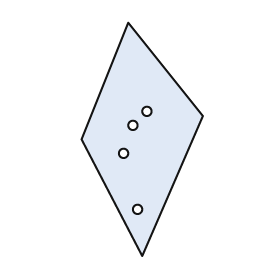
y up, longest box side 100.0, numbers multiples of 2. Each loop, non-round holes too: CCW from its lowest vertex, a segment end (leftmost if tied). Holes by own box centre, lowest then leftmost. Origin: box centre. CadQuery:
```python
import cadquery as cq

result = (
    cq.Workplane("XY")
    .moveTo(0.0, -50.0)
    .lineTo(26.0, 10.0)
    .lineTo(-6.0, 50.0)
    .lineTo(-26.0, 0.0)
    .close()
    .moveTo(-2.0, -30.0)
    .circle(2.0)
    .moveTo(-8.0, -6.0)
    .circle(2.0)
    .moveTo(-4.0, 6.0)
    .circle(2.0)
    .moveTo(2.0, 12.0)
    .circle(2.0)
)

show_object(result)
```